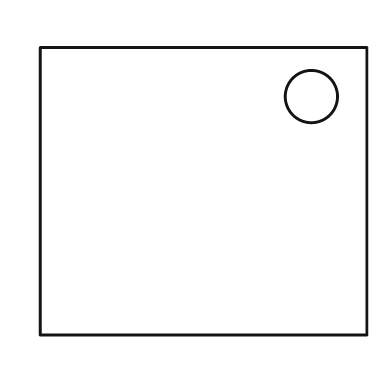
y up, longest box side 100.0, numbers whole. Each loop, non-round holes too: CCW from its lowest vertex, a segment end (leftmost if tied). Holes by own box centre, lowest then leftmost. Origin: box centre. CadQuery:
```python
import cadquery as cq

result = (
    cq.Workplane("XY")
    .moveTo(-50.0, -44.0)
    .lineTo(50.0, -44.0)
    .lineTo(50.0, 44.0)
    .lineTo(-50.0, 44.0)
    .close()
    .moveTo(33.0, 29.0)
    .circle(8.0)
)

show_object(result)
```